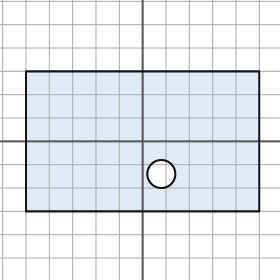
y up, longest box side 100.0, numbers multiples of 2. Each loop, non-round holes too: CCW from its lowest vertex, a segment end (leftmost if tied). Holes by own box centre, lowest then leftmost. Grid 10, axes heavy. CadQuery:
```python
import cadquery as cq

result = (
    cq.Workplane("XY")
    .moveTo(-50.0, -30.0)
    .lineTo(50.0, -30.0)
    .lineTo(50.0, 30.0)
    .lineTo(-50.0, 30.0)
    .close()
    .moveTo(8.0, -14.0)
    .circle(6.0)
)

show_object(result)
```